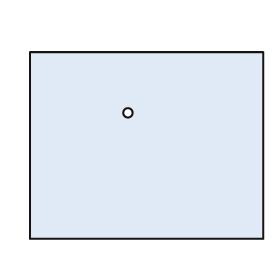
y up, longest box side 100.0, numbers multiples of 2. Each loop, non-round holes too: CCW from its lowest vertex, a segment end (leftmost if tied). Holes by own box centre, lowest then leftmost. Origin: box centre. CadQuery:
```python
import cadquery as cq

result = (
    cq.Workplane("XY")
    .moveTo(-50.0, -40.0)
    .lineTo(50.0, -40.0)
    .lineTo(50.0, 40.0)
    .lineTo(-50.0, 40.0)
    .close()
    .moveTo(-8.0, 14.0)
    .circle(2.0)
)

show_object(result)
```